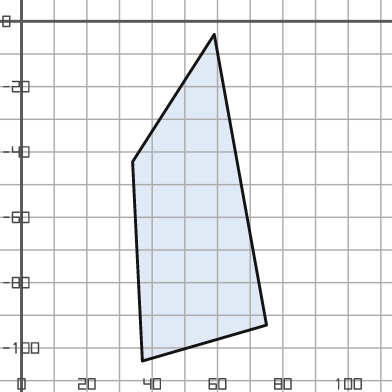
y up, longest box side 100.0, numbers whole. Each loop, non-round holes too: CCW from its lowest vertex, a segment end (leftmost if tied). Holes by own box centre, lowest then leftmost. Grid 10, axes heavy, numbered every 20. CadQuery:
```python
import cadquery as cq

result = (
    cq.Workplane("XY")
    .moveTo(37.0, -104.0)
    .lineTo(75.0, -93.0)
    .lineTo(59.0, -4.0)
    .lineTo(34.0, -43.0)
    .close()
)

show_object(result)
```